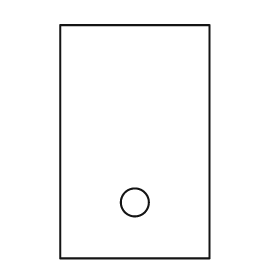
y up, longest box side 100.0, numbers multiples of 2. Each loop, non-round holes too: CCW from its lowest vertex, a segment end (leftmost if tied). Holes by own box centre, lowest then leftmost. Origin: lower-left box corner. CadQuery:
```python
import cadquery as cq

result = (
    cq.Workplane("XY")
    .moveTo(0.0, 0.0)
    .lineTo(64.0, 0.0)
    .lineTo(64.0, 100.0)
    .lineTo(0.0, 100.0)
    .close()
    .moveTo(32.0, 24.0)
    .circle(6.0)
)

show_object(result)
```